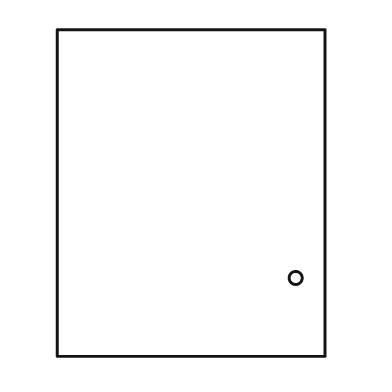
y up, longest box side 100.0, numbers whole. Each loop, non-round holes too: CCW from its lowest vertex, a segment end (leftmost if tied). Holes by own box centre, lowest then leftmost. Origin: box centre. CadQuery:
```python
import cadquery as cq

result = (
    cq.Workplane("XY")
    .moveTo(-41.0, -50.0)
    .lineTo(41.0, -50.0)
    .lineTo(41.0, 50.0)
    .lineTo(-41.0, 50.0)
    .close()
    .moveTo(32.0, -26.0)
    .circle(2.0)
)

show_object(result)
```